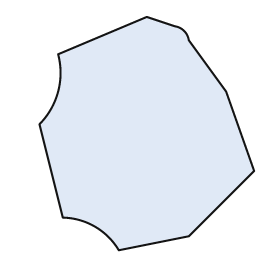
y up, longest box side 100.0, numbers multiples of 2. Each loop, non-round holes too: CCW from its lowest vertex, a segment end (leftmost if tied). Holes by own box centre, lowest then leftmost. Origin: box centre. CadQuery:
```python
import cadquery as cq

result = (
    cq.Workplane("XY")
    .moveTo(-12.0, -50.0)
    .lineTo(18.0, -44.0)
    .lineTo(46.0, -16.0)
    .lineTo(34.0, 18.0)
    .lineTo(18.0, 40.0)
    .threePointArc((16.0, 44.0), (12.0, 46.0))
    .lineTo(0.0, 50.0)
    .lineTo(-38.0, 34.0)
    .threePointArc((-38.0, 18.0), (-46.0, 4.0))
    .lineTo(-36.0, -36.0)
    .threePointArc((-22.0, -40.0), (-12.0, -50.0))
    .close()
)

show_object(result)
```